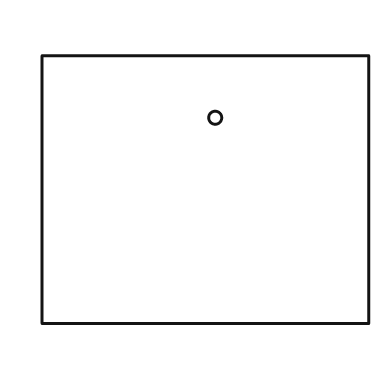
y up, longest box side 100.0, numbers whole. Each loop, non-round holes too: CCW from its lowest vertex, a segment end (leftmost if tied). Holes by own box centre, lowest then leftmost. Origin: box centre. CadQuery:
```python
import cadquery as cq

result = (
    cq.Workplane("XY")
    .moveTo(-50.0, -41.0)
    .lineTo(50.0, -41.0)
    .lineTo(50.0, 41.0)
    .lineTo(-50.0, 41.0)
    .close()
    .moveTo(3.0, 22.0)
    .circle(2.0)
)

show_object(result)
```